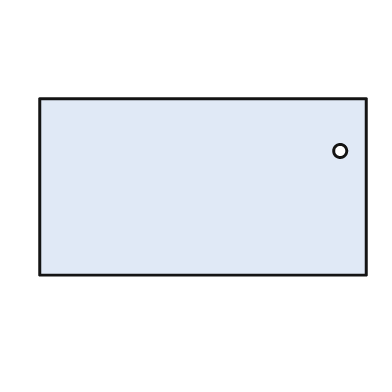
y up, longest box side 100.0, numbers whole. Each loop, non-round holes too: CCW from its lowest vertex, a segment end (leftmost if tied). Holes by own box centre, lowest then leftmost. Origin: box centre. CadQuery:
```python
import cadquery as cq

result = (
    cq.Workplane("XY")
    .moveTo(-50.0, -27.0)
    .lineTo(50.0, -27.0)
    .lineTo(50.0, 27.0)
    .lineTo(-50.0, 27.0)
    .close()
    .moveTo(42.0, 11.0)
    .circle(2.0)
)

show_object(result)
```